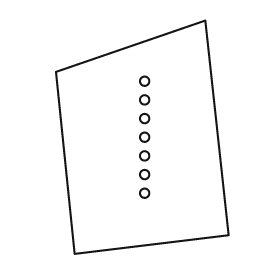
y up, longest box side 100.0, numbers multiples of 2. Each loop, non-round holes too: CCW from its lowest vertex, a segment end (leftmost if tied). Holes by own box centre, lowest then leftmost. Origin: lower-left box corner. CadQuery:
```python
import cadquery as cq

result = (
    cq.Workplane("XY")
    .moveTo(8.0, 0.0)
    .lineTo(74.0, 8.0)
    .lineTo(64.0, 100.0)
    .lineTo(0.0, 78.0)
    .close()
    .moveTo(38.0, 26.0)
    .circle(2.0)
    .moveTo(38.0, 34.0)
    .circle(2.0)
    .moveTo(38.0, 42.0)
    .circle(2.0)
    .moveTo(38.0, 50.0)
    .circle(2.0)
    .moveTo(38.0, 58.0)
    .circle(2.0)
    .moveTo(38.0, 66.0)
    .circle(2.0)
    .moveTo(38.0, 74.0)
    .circle(2.0)
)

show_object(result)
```